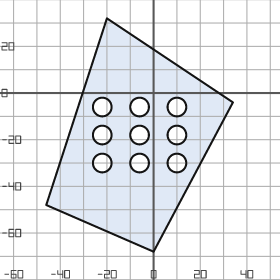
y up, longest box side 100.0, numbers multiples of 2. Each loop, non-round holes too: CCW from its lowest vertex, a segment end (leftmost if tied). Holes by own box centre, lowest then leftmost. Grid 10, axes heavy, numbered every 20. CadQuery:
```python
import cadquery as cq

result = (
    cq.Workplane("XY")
    .moveTo(0.0, -68.0)
    .lineTo(34.0, -4.0)
    .lineTo(-20.0, 32.0)
    .lineTo(-46.0, -48.0)
    .close()
    .moveTo(-22.0, -30.0)
    .circle(4.0)
    .moveTo(-6.0, -30.0)
    .circle(4.0)
    .moveTo(10.0, -30.0)
    .circle(4.0)
    .moveTo(-22.0, -18.0)
    .circle(4.0)
    .moveTo(-6.0, -18.0)
    .circle(4.0)
    .moveTo(10.0, -18.0)
    .circle(4.0)
    .moveTo(-22.0, -6.0)
    .circle(4.0)
    .moveTo(-6.0, -6.0)
    .circle(4.0)
    .moveTo(10.0, -6.0)
    .circle(4.0)
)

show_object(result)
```